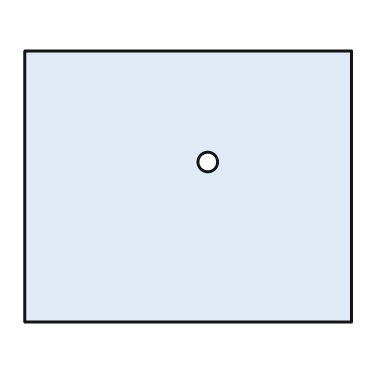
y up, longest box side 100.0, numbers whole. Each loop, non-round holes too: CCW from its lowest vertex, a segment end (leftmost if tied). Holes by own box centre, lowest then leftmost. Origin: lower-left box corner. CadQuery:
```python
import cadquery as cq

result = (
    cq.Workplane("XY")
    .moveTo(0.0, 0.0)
    .lineTo(100.0, 0.0)
    .lineTo(100.0, 83.0)
    .lineTo(0.0, 83.0)
    .close()
    .moveTo(56.0, 49.0)
    .circle(3.0)
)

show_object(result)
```